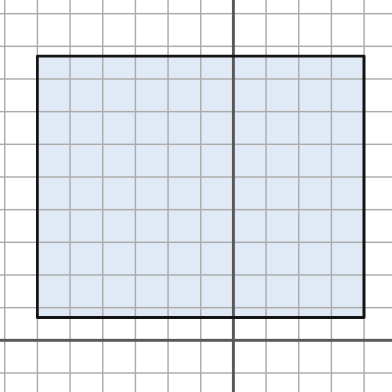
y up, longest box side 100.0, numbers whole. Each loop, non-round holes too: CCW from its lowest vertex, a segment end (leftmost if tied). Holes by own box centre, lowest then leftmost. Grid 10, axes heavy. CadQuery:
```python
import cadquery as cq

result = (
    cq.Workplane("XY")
    .moveTo(-60.0, 7.0)
    .lineTo(40.0, 7.0)
    .lineTo(40.0, 87.0)
    .lineTo(-60.0, 87.0)
    .close()
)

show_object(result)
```